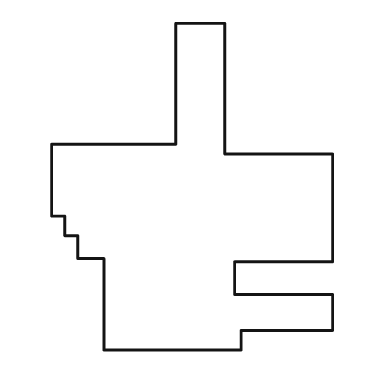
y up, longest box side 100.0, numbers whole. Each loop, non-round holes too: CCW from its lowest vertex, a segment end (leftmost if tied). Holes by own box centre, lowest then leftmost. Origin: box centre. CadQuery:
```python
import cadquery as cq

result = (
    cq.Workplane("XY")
    .moveTo(-27.0, -50.0)
    .lineTo(15.0, -50.0)
    .lineTo(15.0, -44.0)
    .lineTo(43.0, -44.0)
    .lineTo(43.0, -33.0)
    .lineTo(13.0, -33.0)
    .lineTo(13.0, -23.0)
    .lineTo(43.0, -23.0)
    .lineTo(43.0, 10.0)
    .lineTo(10.0, 10.0)
    .lineTo(10.0, 50.0)
    .lineTo(-5.0, 50.0)
    .lineTo(-5.0, 13.0)
    .lineTo(-43.0, 13.0)
    .lineTo(-43.0, -9.0)
    .lineTo(-39.0, -9.0)
    .lineTo(-39.0, -15.0)
    .lineTo(-35.0, -15.0)
    .lineTo(-35.0, -22.0)
    .lineTo(-27.0, -22.0)
    .close()
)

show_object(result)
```